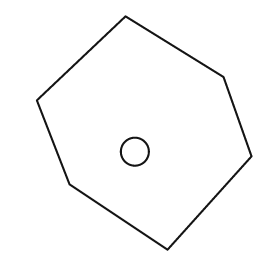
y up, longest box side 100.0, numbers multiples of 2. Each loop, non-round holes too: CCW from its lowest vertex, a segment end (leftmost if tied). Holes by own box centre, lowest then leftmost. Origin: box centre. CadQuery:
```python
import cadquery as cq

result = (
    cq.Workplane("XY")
    .moveTo(10.0, -50.0)
    .lineTo(46.0, -10.0)
    .lineTo(34.0, 24.0)
    .lineTo(-8.0, 50.0)
    .lineTo(-46.0, 14.0)
    .lineTo(-32.0, -22.0)
    .close()
    .moveTo(-4.0, -8.0)
    .circle(6.0)
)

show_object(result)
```